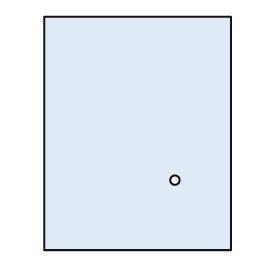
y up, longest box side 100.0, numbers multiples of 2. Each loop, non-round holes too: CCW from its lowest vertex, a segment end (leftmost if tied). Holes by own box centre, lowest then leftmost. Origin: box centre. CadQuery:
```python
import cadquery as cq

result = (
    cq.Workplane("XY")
    .moveTo(-40.0, -50.0)
    .lineTo(40.0, -50.0)
    .lineTo(40.0, 50.0)
    .lineTo(-40.0, 50.0)
    .close()
    .moveTo(16.0, -20.0)
    .circle(2.0)
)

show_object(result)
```